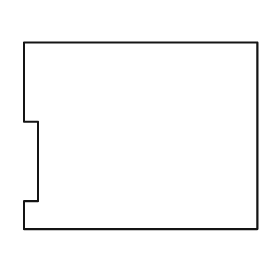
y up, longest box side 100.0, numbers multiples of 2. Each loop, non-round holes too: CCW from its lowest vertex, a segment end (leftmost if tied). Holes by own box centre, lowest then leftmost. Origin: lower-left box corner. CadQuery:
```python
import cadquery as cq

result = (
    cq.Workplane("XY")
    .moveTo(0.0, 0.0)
    .lineTo(100.0, 0.0)
    .lineTo(100.0, 80.0)
    .lineTo(0.0, 80.0)
    .lineTo(0.0, 46.0)
    .lineTo(6.0, 46.0)
    .lineTo(6.0, 12.0)
    .lineTo(0.0, 12.0)
    .close()
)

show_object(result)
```